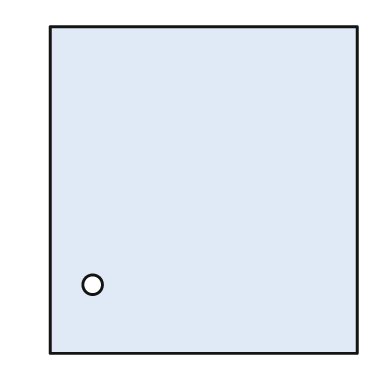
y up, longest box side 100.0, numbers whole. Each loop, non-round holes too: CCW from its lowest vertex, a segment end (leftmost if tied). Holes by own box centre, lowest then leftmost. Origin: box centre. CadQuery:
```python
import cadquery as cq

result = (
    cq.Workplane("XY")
    .moveTo(-47.0, -50.0)
    .lineTo(47.0, -50.0)
    .lineTo(47.0, 50.0)
    .lineTo(-47.0, 50.0)
    .close()
    .moveTo(-34.0, -29.0)
    .circle(3.0)
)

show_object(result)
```